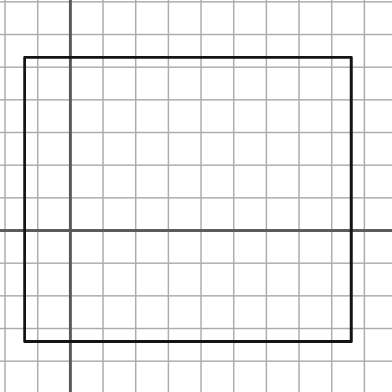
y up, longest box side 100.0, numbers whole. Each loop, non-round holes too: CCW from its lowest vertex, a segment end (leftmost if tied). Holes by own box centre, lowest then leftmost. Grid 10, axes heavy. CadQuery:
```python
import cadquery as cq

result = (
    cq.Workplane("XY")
    .moveTo(-14.0, -34.0)
    .lineTo(86.0, -34.0)
    .lineTo(86.0, 53.0)
    .lineTo(-14.0, 53.0)
    .close()
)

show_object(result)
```